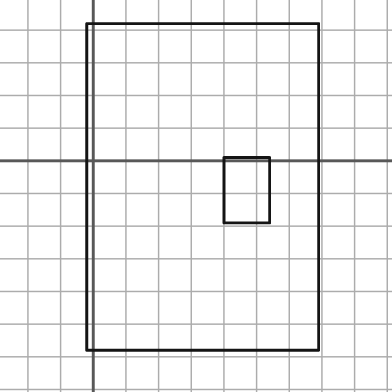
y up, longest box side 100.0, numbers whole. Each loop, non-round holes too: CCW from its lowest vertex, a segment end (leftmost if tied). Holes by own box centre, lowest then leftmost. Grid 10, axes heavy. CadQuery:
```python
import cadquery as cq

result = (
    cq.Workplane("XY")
    .moveTo(-2.0, -58.0)
    .lineTo(69.0, -58.0)
    .lineTo(69.0, 42.0)
    .lineTo(-2.0, 42.0)
    .close()
    .moveTo(40.0, -19.0)
    .lineTo(54.0, -19.0)
    .lineTo(54.0, 1.0)
    .lineTo(40.0, 1.0)
    .close()
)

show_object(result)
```